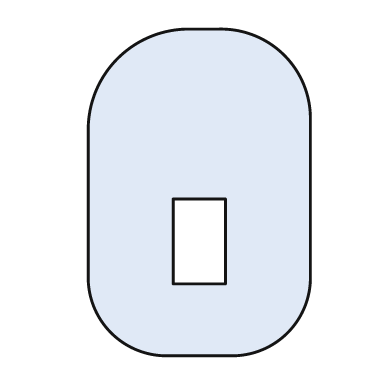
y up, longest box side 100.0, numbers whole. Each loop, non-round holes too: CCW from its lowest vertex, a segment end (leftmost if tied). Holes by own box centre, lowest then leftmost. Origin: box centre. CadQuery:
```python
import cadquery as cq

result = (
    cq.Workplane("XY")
    .moveTo(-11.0, -50.0)
    .lineTo(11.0, -50.0)
    .threePointArc((27.0, -43.0), (34.0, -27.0))
    .lineTo(34.0, 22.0)
    .threePointArc((26.0, 42.0), (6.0, 50.0))
    .lineTo(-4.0, 50.0)
    .threePointArc((-25.0, 41.0), (-34.0, 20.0))
    .lineTo(-34.0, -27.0)
    .threePointArc((-27.0, -43.0), (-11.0, -50.0))
    .close()
    .moveTo(-8.0, -28.0)
    .lineTo(8.0, -28.0)
    .lineTo(8.0, -2.0)
    .lineTo(-8.0, -2.0)
    .close()
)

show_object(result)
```